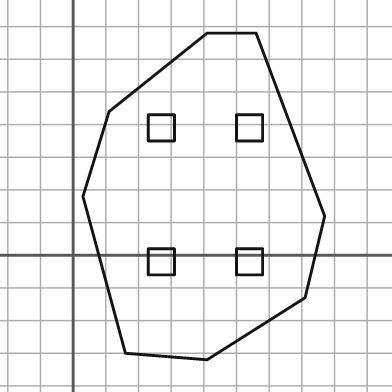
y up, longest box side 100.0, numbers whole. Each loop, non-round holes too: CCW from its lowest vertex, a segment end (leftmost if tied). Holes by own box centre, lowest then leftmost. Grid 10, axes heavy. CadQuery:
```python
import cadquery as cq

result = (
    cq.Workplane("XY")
    .moveTo(41.0, -32.0)
    .lineTo(71.0, -13.0)
    .lineTo(77.0, 12.0)
    .lineTo(56.0, 68.0)
    .lineTo(41.0, 68.0)
    .lineTo(11.0, 44.0)
    .lineTo(3.0, 18.0)
    .lineTo(16.0, -30.0)
    .close()
    .moveTo(23.0, -6.0)
    .lineTo(31.0, -6.0)
    .lineTo(31.0, 2.0)
    .lineTo(23.0, 2.0)
    .close()
    .moveTo(50.0, -6.0)
    .lineTo(58.0, -6.0)
    .lineTo(58.0, 2.0)
    .lineTo(50.0, 2.0)
    .close()
    .moveTo(23.0, 35.0)
    .lineTo(31.0, 35.0)
    .lineTo(31.0, 43.0)
    .lineTo(23.0, 43.0)
    .close()
    .moveTo(50.0, 35.0)
    .lineTo(58.0, 35.0)
    .lineTo(58.0, 43.0)
    .lineTo(50.0, 43.0)
    .close()
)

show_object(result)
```